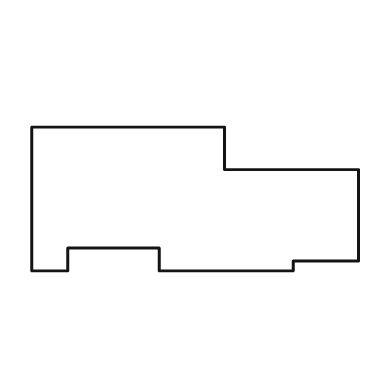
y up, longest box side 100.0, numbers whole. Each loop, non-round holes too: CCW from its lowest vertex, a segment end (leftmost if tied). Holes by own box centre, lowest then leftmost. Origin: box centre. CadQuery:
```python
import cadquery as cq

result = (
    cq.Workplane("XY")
    .moveTo(-50.0, -22.0)
    .lineTo(-39.0, -22.0)
    .lineTo(-39.0, -15.0)
    .lineTo(-11.0, -15.0)
    .lineTo(-11.0, -22.0)
    .lineTo(30.0, -22.0)
    .lineTo(30.0, -19.0)
    .lineTo(50.0, -19.0)
    .lineTo(50.0, 9.0)
    .lineTo(9.0, 9.0)
    .lineTo(9.0, 22.0)
    .lineTo(-50.0, 22.0)
    .close()
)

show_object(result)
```